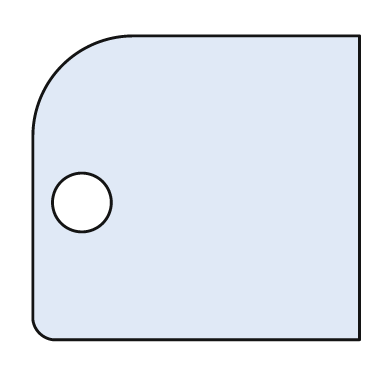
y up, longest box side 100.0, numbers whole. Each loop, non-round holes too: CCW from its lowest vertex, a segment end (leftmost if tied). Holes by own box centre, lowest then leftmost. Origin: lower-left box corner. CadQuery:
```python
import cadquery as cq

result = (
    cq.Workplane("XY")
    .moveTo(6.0, 0.0)
    .lineTo(100.0, 0.0)
    .lineTo(100.0, 93.0)
    .lineTo(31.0, 93.0)
    .threePointArc((9.0, 84.0), (0.0, 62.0))
    .lineTo(0.0, 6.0)
    .threePointArc((2.0, 2.0), (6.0, 0.0))
    .close()
    .moveTo(15.0, 42.0)
    .circle(9.0)
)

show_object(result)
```